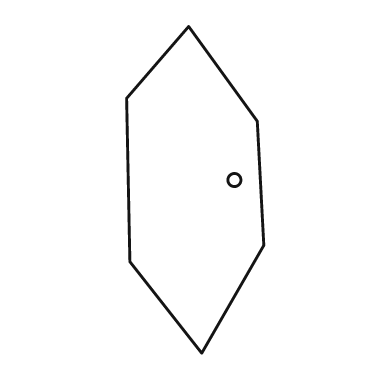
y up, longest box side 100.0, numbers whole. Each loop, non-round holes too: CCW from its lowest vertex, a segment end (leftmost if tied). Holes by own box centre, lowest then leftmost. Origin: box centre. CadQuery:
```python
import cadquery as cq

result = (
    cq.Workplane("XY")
    .moveTo(2.0, -50.0)
    .lineTo(21.0, -17.0)
    .lineTo(19.0, 21.0)
    .lineTo(-2.0, 50.0)
    .lineTo(-21.0, 28.0)
    .lineTo(-20.0, -22.0)
    .close()
    .moveTo(12.0, 3.0)
    .circle(2.0)
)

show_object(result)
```